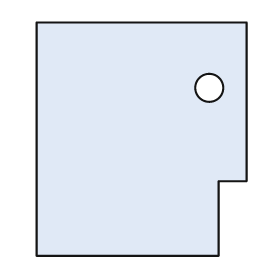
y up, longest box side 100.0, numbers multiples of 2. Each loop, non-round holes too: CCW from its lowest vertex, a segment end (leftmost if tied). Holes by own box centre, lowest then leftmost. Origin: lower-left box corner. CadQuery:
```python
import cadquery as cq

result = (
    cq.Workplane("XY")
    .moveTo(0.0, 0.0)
    .lineTo(78.0, 0.0)
    .lineTo(78.0, 32.0)
    .lineTo(90.0, 32.0)
    .lineTo(90.0, 100.0)
    .lineTo(0.0, 100.0)
    .close()
    .moveTo(74.0, 72.0)
    .circle(6.0)
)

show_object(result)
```